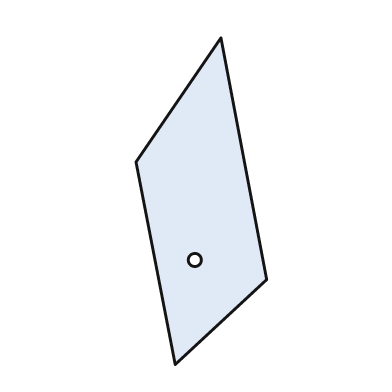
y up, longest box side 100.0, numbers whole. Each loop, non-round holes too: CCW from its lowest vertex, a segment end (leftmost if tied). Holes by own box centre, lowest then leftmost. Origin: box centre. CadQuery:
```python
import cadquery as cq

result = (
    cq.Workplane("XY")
    .moveTo(-8.0, -50.0)
    .lineTo(20.0, -24.0)
    .lineTo(6.0, 50.0)
    .lineTo(-20.0, 12.0)
    .close()
    .moveTo(-2.0, -18.0)
    .circle(2.0)
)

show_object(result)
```